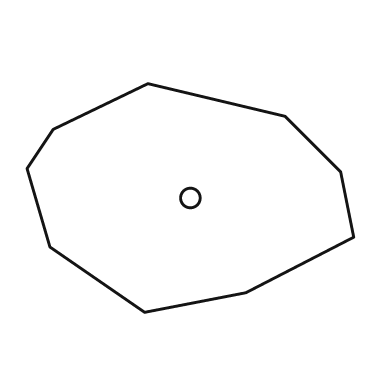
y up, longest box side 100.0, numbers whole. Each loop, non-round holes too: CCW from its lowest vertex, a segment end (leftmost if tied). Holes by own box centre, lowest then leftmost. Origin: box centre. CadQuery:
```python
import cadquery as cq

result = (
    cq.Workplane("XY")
    .moveTo(-14.0, -35.0)
    .lineTo(17.0, -29.0)
    .lineTo(50.0, -12.0)
    .lineTo(46.0, 8.0)
    .lineTo(29.0, 25.0)
    .lineTo(-13.0, 35.0)
    .lineTo(-42.0, 21.0)
    .lineTo(-50.0, 9.0)
    .lineTo(-43.0, -15.0)
    .close()
    .moveTo(0.0, 0.0)
    .circle(3.0)
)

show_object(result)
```